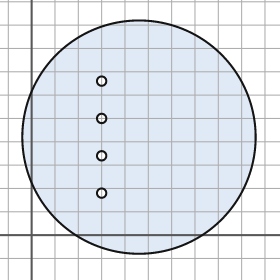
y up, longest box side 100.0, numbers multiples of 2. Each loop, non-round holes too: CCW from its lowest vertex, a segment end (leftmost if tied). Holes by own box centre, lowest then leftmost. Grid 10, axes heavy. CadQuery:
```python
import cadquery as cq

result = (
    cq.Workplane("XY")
    .moveTo(46.0, 42.0)
    .circle(50.0)
    .moveTo(30.0, 18.0)
    .circle(2.0)
    .moveTo(30.0, 34.0)
    .circle(2.0)
    .moveTo(30.0, 50.0)
    .circle(2.0)
    .moveTo(30.0, 66.0)
    .circle(2.0)
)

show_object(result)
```